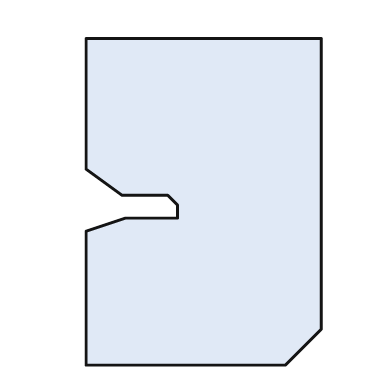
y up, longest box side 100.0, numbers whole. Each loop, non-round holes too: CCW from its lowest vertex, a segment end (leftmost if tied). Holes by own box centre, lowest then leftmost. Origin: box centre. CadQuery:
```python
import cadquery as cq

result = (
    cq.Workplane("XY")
    .moveTo(-36.0, -50.0)
    .lineTo(25.0, -50.0)
    .lineTo(36.0, -39.0)
    .lineTo(36.0, 50.0)
    .lineTo(-36.0, 50.0)
    .lineTo(-36.0, 10.0)
    .lineTo(-25.0, 2.0)
    .lineTo(-11.0, 2.0)
    .lineTo(-8.0, -1.0)
    .lineTo(-8.0, -5.0)
    .lineTo(-24.0, -5.0)
    .lineTo(-36.0, -9.0)
    .close()
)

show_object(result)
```